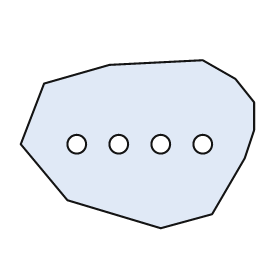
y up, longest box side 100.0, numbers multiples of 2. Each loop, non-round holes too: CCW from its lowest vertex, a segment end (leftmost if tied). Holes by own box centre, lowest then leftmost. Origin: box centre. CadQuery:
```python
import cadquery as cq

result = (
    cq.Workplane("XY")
    .moveTo(10.0, -36.0)
    .lineTo(32.0, -30.0)
    .lineTo(46.0, -6.0)
    .lineTo(50.0, 6.0)
    .lineTo(50.0, 18.0)
    .lineTo(42.0, 28.0)
    .lineTo(28.0, 36.0)
    .lineTo(-12.0, 34.0)
    .lineTo(-40.0, 26.0)
    .lineTo(-50.0, 0.0)
    .lineTo(-30.0, -24.0)
    .close()
    .moveTo(-26.0, 0.0)
    .circle(4.0)
    .moveTo(-8.0, 0.0)
    .circle(4.0)
    .moveTo(10.0, 0.0)
    .circle(4.0)
    .moveTo(28.0, 0.0)
    .circle(4.0)
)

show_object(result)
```